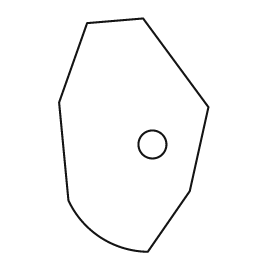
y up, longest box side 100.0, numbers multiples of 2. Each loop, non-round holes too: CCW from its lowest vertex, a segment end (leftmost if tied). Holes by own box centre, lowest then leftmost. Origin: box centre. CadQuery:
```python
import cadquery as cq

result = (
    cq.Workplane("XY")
    .moveTo(6.0, -50.0)
    .lineTo(24.0, -24.0)
    .lineTo(32.0, 12.0)
    .lineTo(4.0, 50.0)
    .lineTo(-20.0, 48.0)
    .lineTo(-32.0, 14.0)
    .lineTo(-28.0, -28.0)
    .threePointArc((-14.0, -44.0), (6.0, -50.0))
    .close()
    .moveTo(8.0, -4.0)
    .circle(6.0)
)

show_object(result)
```